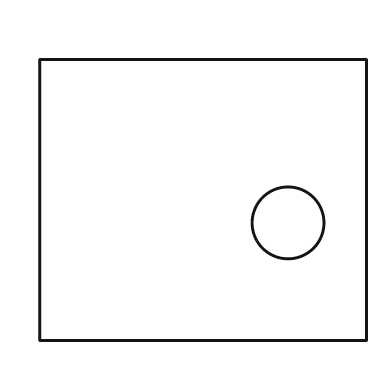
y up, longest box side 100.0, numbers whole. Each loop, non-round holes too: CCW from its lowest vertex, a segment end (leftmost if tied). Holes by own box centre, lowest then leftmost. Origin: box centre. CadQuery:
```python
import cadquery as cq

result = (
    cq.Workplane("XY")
    .moveTo(-50.0, -43.0)
    .lineTo(50.0, -43.0)
    .lineTo(50.0, 43.0)
    .lineTo(-50.0, 43.0)
    .close()
    .moveTo(26.0, -7.0)
    .circle(11.0)
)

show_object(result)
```